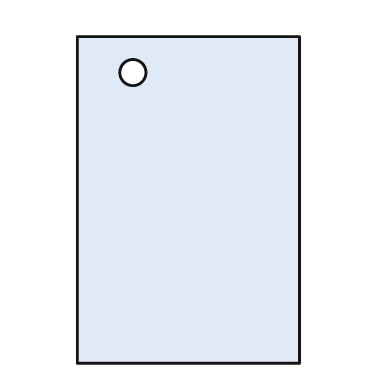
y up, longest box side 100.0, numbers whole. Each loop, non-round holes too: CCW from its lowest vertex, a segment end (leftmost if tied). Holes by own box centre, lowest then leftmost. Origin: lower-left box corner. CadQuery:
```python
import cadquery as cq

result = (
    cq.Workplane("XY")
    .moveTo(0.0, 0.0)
    .lineTo(68.0, 0.0)
    .lineTo(68.0, 100.0)
    .lineTo(0.0, 100.0)
    .close()
    .moveTo(17.0, 89.0)
    .circle(4.0)
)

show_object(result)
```